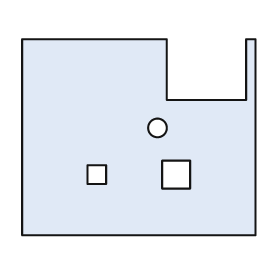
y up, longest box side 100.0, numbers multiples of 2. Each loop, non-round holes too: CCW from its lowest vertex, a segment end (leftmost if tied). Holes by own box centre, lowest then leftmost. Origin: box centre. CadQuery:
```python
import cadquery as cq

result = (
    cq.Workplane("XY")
    .moveTo(-50.0, -42.0)
    .lineTo(50.0, -42.0)
    .lineTo(50.0, 42.0)
    .lineTo(46.0, 42.0)
    .lineTo(46.0, 16.0)
    .lineTo(12.0, 16.0)
    .lineTo(12.0, 42.0)
    .lineTo(-50.0, 42.0)
    .close()
    .moveTo(-22.0, -20.0)
    .lineTo(-14.0, -20.0)
    .lineTo(-14.0, -12.0)
    .lineTo(-22.0, -12.0)
    .close()
    .moveTo(10.0, -22.0)
    .lineTo(22.0, -22.0)
    .lineTo(22.0, -10.0)
    .lineTo(10.0, -10.0)
    .close()
    .moveTo(8.0, 4.0)
    .circle(4.0)
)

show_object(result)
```